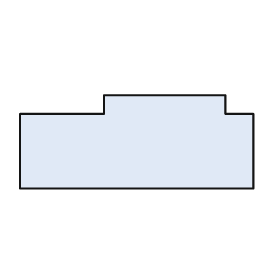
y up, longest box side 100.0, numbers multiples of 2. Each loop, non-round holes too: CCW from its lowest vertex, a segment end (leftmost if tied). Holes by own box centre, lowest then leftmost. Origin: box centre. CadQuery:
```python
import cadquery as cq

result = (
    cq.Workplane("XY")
    .moveTo(-50.0, -20.0)
    .lineTo(50.0, -20.0)
    .lineTo(50.0, 12.0)
    .lineTo(38.0, 12.0)
    .lineTo(38.0, 20.0)
    .lineTo(-14.0, 20.0)
    .lineTo(-14.0, 12.0)
    .lineTo(-50.0, 12.0)
    .close()
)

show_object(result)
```